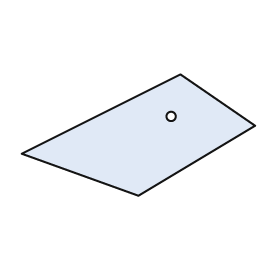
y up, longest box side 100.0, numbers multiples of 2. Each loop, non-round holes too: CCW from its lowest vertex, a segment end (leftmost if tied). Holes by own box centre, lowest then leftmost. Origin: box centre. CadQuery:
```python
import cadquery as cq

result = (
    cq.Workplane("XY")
    .moveTo(0.0, -26.0)
    .lineTo(50.0, 4.0)
    .lineTo(18.0, 26.0)
    .lineTo(-50.0, -8.0)
    .close()
    .moveTo(14.0, 8.0)
    .circle(2.0)
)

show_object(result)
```